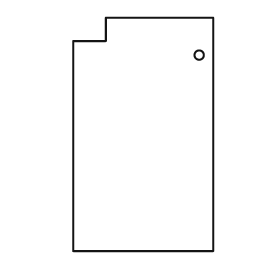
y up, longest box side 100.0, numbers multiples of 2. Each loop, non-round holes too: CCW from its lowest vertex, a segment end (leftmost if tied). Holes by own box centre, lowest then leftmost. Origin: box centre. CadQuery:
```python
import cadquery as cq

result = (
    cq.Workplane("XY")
    .moveTo(-30.0, -50.0)
    .lineTo(30.0, -50.0)
    .lineTo(30.0, 50.0)
    .lineTo(-16.0, 50.0)
    .lineTo(-16.0, 40.0)
    .lineTo(-30.0, 40.0)
    .close()
    .moveTo(24.0, 34.0)
    .circle(2.0)
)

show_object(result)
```